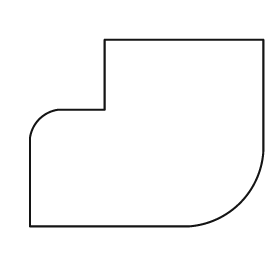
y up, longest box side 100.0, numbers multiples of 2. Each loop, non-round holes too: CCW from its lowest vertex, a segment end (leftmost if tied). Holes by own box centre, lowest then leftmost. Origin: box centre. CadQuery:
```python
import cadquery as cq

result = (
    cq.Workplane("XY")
    .moveTo(-50.0, -40.0)
    .lineTo(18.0, -40.0)
    .threePointArc((40.0, -30.0), (50.0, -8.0))
    .lineTo(50.0, 40.0)
    .lineTo(-18.0, 40.0)
    .lineTo(-18.0, 10.0)
    .lineTo(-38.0, 10.0)
    .threePointArc((-46.0, 6.0), (-50.0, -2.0))
    .close()
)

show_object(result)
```